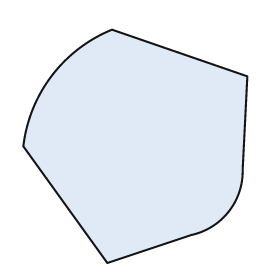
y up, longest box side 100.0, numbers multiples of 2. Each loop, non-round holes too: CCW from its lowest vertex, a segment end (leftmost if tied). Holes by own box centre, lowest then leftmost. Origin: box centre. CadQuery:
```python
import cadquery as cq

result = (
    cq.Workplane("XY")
    .moveTo(-12.0, -50.0)
    .lineTo(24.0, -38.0)
    .threePointArc((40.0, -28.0), (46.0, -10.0))
    .lineTo(48.0, 30.0)
    .lineTo(-10.0, 50.0)
    .threePointArc((-36.0, 30.0), (-48.0, 0.0))
    .close()
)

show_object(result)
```